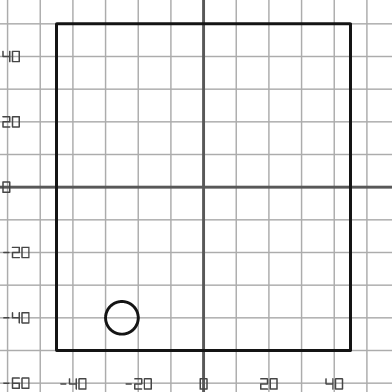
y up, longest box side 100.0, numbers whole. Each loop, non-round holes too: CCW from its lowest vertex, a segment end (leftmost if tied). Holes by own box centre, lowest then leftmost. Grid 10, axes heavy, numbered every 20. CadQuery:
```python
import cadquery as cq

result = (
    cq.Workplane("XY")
    .moveTo(-45.0, -50.0)
    .lineTo(45.0, -50.0)
    .lineTo(45.0, 50.0)
    .lineTo(-45.0, 50.0)
    .close()
    .moveTo(-25.0, -40.0)
    .circle(5.0)
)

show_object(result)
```